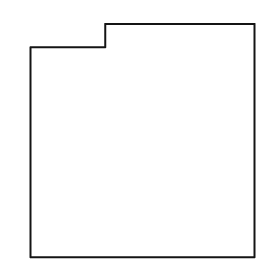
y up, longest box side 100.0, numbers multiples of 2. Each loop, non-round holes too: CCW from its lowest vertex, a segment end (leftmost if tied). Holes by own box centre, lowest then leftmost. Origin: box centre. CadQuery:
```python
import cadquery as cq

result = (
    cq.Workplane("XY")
    .moveTo(-48.0, -50.0)
    .lineTo(48.0, -50.0)
    .lineTo(48.0, 50.0)
    .lineTo(-16.0, 50.0)
    .lineTo(-16.0, 40.0)
    .lineTo(-48.0, 40.0)
    .close()
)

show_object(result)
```